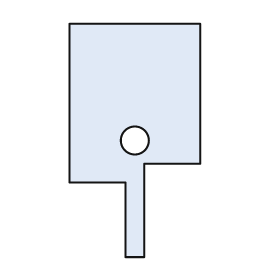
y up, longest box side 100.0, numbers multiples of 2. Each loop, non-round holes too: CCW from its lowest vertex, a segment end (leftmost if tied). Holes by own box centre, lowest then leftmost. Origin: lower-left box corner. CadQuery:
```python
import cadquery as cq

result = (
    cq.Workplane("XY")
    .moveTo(24.0, 0.0)
    .lineTo(32.0, 0.0)
    .lineTo(32.0, 40.0)
    .lineTo(56.0, 40.0)
    .lineTo(56.0, 100.0)
    .lineTo(0.0, 100.0)
    .lineTo(0.0, 32.0)
    .lineTo(24.0, 32.0)
    .close()
    .moveTo(28.0, 50.0)
    .circle(6.0)
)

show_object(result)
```